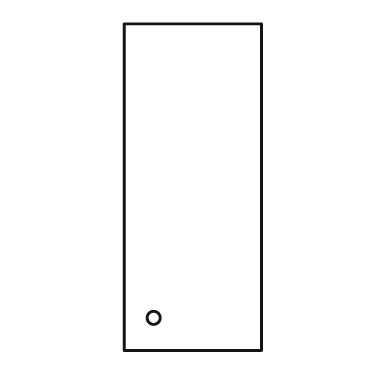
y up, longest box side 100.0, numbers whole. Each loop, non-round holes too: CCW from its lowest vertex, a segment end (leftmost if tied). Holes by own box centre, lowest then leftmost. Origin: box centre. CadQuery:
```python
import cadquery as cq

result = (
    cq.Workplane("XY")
    .moveTo(-21.0, -50.0)
    .lineTo(21.0, -50.0)
    .lineTo(21.0, 50.0)
    .lineTo(-21.0, 50.0)
    .close()
    .moveTo(-12.0, -40.0)
    .circle(2.0)
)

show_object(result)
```